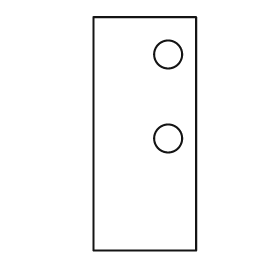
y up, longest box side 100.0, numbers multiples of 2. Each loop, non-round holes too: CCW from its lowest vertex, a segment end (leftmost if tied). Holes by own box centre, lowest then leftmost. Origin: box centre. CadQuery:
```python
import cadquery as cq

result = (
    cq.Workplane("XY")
    .moveTo(-22.0, -50.0)
    .lineTo(22.0, -50.0)
    .lineTo(22.0, 50.0)
    .lineTo(-22.0, 50.0)
    .close()
    .moveTo(10.0, -2.0)
    .circle(6.0)
    .moveTo(10.0, 34.0)
    .circle(6.0)
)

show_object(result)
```